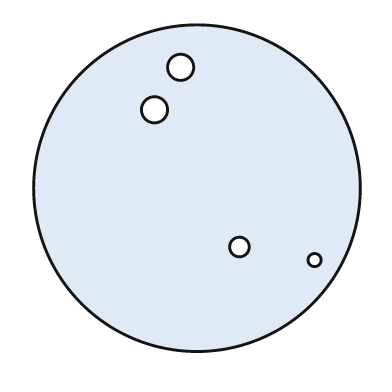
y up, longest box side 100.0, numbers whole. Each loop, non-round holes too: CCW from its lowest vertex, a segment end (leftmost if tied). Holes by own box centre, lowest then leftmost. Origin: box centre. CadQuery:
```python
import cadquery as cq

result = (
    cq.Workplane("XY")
    .moveTo(0.0, 0.0)
    .circle(50.0)
    .moveTo(36.0, -22.0)
    .circle(2.0)
    .moveTo(13.0, -18.0)
    .circle(3.0)
    .moveTo(-13.0, 24.0)
    .circle(4.0)
    .moveTo(-5.0, 37.0)
    .circle(4.0)
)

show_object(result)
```